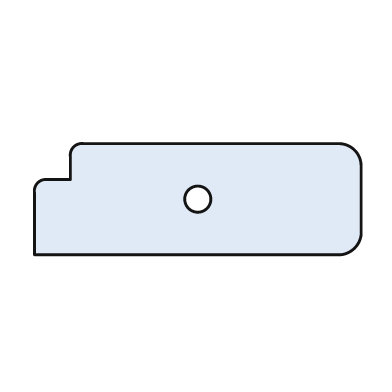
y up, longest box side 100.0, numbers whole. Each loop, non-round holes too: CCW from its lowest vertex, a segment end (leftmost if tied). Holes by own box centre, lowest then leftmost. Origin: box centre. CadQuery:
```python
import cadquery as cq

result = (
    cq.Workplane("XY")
    .moveTo(-50.0, -17.0)
    .lineTo(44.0, -17.0)
    .threePointArc((48.0, -15.0), (50.0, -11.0))
    .lineTo(50.0, 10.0)
    .threePointArc((48.0, 15.0), (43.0, 17.0))
    .lineTo(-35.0, 17.0)
    .threePointArc((-38.0, 16.0), (-39.0, 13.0))
    .lineTo(-39.0, 6.0)
    .lineTo(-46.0, 6.0)
    .threePointArc((-49.0, 5.0), (-50.0, 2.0))
    .close()
    .moveTo(0.0, 0.0)
    .circle(4.0)
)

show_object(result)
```